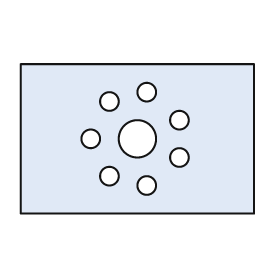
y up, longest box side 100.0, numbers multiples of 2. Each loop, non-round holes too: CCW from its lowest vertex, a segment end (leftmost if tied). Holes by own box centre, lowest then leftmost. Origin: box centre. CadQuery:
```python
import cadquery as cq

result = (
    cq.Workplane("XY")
    .moveTo(-50.0, -32.0)
    .lineTo(50.0, -32.0)
    .lineTo(50.0, 32.0)
    .lineTo(-50.0, 32.0)
    .close()
    .moveTo(4.0, -20.0)
    .circle(4.0)
    .moveTo(-12.0, -16.0)
    .circle(4.0)
    .moveTo(18.0, -8.0)
    .circle(4.0)
    .moveTo(-20.0, 0.0)
    .circle(4.0)
    .moveTo(0.0, 0.0)
    .circle(8.0)
    .moveTo(18.0, 8.0)
    .circle(4.0)
    .moveTo(-12.0, 16.0)
    .circle(4.0)
    .moveTo(4.0, 20.0)
    .circle(4.0)
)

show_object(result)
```